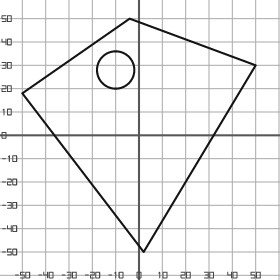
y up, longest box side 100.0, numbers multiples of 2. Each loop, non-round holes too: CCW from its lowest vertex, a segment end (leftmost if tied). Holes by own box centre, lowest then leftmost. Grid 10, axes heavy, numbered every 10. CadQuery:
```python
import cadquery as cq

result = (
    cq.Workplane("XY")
    .moveTo(2.0, -50.0)
    .lineTo(50.0, 30.0)
    .lineTo(-4.0, 50.0)
    .lineTo(-50.0, 18.0)
    .close()
    .moveTo(-10.0, 28.0)
    .circle(8.0)
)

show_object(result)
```